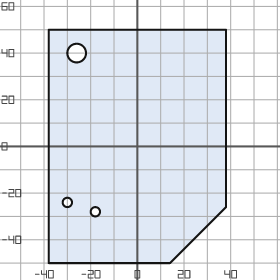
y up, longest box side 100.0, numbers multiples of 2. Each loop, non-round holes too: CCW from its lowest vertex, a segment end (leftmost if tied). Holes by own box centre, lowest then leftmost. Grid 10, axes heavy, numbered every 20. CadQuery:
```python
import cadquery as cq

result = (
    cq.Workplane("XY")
    .moveTo(-38.0, -50.0)
    .lineTo(14.0, -50.0)
    .lineTo(38.0, -26.0)
    .lineTo(38.0, 50.0)
    .lineTo(-38.0, 50.0)
    .close()
    .moveTo(-18.0, -28.0)
    .circle(2.0)
    .moveTo(-30.0, -24.0)
    .circle(2.0)
    .moveTo(-26.0, 40.0)
    .circle(4.0)
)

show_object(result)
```